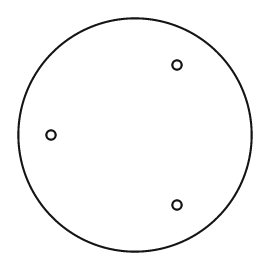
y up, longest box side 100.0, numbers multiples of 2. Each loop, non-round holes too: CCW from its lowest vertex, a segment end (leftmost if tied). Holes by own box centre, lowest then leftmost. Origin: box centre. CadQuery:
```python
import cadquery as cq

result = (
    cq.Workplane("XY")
    .moveTo(0.0, 0.0)
    .circle(50.0)
    .moveTo(18.0, -30.0)
    .circle(2.0)
    .moveTo(-36.0, 0.0)
    .circle(2.0)
    .moveTo(18.0, 30.0)
    .circle(2.0)
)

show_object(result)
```